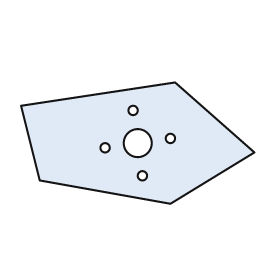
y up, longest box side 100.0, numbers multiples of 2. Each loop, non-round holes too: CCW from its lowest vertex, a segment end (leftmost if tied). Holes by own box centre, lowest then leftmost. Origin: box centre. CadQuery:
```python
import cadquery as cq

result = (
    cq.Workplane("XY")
    .moveTo(14.0, -26.0)
    .lineTo(50.0, -4.0)
    .lineTo(16.0, 26.0)
    .lineTo(-50.0, 16.0)
    .lineTo(-42.0, -16.0)
    .close()
    .moveTo(2.0, -14.0)
    .circle(2.0)
    .moveTo(-14.0, -2.0)
    .circle(2.0)
    .moveTo(0.0, 0.0)
    .circle(6.0)
    .moveTo(14.0, 2.0)
    .circle(2.0)
    .moveTo(-2.0, 14.0)
    .circle(2.0)
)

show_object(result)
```